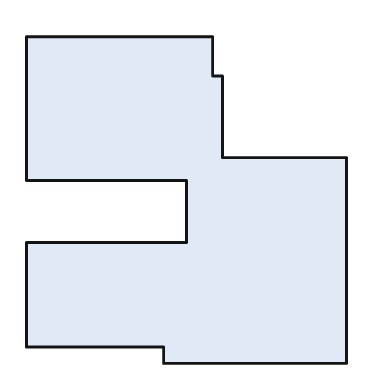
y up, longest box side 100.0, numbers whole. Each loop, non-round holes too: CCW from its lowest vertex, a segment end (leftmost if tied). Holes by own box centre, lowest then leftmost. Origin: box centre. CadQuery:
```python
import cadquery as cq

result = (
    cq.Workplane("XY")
    .moveTo(-7.0, -50.0)
    .lineTo(49.0, -50.0)
    .lineTo(49.0, 13.0)
    .lineTo(11.0, 13.0)
    .lineTo(11.0, 38.0)
    .lineTo(8.0, 38.0)
    .lineTo(8.0, 50.0)
    .lineTo(-49.0, 50.0)
    .lineTo(-49.0, 6.0)
    .lineTo(0.0, 6.0)
    .lineTo(0.0, -13.0)
    .lineTo(-49.0, -13.0)
    .lineTo(-49.0, -45.0)
    .lineTo(-7.0, -45.0)
    .close()
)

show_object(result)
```